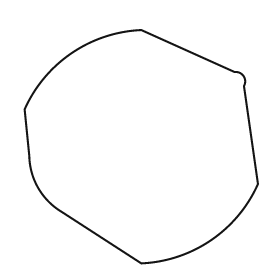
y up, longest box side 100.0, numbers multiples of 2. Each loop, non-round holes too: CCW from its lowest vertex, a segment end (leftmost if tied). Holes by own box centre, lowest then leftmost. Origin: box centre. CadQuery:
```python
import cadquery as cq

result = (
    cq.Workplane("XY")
    .moveTo(0.0, -50.0)
    .threePointArc((30.0, -40.0), (50.0, -16.0))
    .lineTo(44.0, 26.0)
    .threePointArc((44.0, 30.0), (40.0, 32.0))
    .lineTo(0.0, 50.0)
    .threePointArc((-30.0, 40.0), (-50.0, 16.0))
    .lineTo(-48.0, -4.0)
    .threePointArc((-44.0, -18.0), (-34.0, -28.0))
    .close()
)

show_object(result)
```